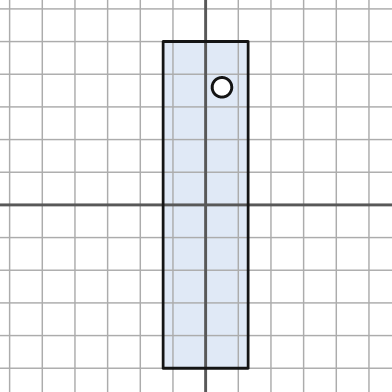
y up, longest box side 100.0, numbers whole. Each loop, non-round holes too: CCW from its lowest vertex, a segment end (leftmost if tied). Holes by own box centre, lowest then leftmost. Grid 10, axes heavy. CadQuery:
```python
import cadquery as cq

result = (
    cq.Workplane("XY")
    .moveTo(-13.0, -50.0)
    .lineTo(13.0, -50.0)
    .lineTo(13.0, 50.0)
    .lineTo(-13.0, 50.0)
    .close()
    .moveTo(5.0, 36.0)
    .circle(3.0)
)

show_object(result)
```